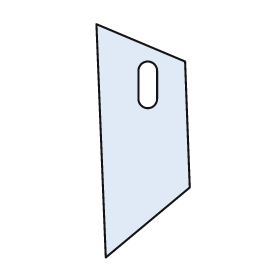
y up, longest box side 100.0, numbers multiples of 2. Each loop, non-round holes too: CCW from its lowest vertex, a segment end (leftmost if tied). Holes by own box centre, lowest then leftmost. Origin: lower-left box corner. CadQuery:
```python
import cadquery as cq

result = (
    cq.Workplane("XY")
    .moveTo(4.0, 0.0)
    .lineTo(40.0, 30.0)
    .lineTo(38.0, 84.0)
    .lineTo(0.0, 100.0)
    .close()
    .moveTo(18.0, 68.0)
    .threePointArc((22.0, 64.0), (26.0, 68.0))
    .lineTo(26.0, 80.0)
    .threePointArc((22.0, 84.0), (18.0, 80.0))
    .close()
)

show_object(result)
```